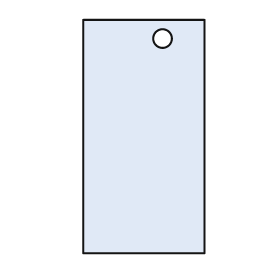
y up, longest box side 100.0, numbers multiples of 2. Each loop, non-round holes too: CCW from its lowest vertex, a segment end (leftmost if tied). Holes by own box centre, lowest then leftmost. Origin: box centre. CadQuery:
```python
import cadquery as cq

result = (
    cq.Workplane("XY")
    .moveTo(-26.0, -50.0)
    .lineTo(26.0, -50.0)
    .lineTo(26.0, 50.0)
    .lineTo(-26.0, 50.0)
    .close()
    .moveTo(8.0, 42.0)
    .circle(4.0)
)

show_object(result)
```